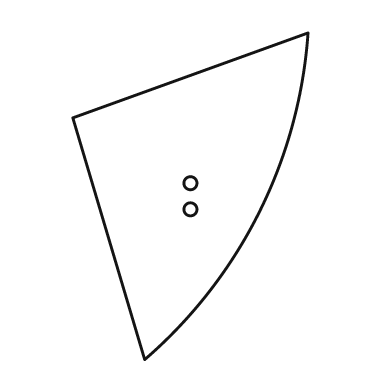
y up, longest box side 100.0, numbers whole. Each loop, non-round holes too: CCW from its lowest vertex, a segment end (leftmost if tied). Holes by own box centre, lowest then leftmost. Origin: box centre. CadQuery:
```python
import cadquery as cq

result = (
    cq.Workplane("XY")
    .moveTo(-14.0, -50.0)
    .threePointArc((21.0, -5.0), (36.0, 50.0))
    .lineTo(-36.0, 24.0)
    .close()
    .moveTo(0.0, -4.0)
    .circle(2.0)
    .moveTo(0.0, 4.0)
    .circle(2.0)
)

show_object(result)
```